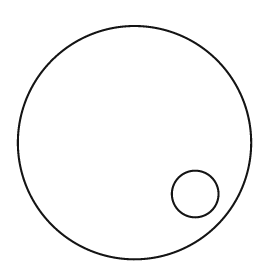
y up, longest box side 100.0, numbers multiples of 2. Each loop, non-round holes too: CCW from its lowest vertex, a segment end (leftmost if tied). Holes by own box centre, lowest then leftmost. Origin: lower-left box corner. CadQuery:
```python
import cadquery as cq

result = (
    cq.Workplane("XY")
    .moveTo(50.0, 50.0)
    .circle(50.0)
    .moveTo(76.0, 28.0)
    .circle(10.0)
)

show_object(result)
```